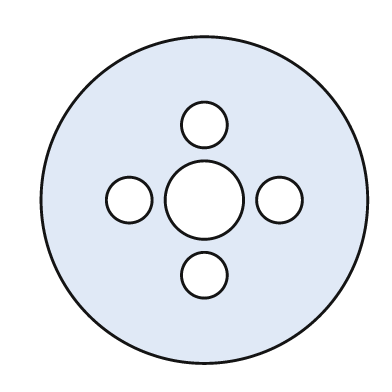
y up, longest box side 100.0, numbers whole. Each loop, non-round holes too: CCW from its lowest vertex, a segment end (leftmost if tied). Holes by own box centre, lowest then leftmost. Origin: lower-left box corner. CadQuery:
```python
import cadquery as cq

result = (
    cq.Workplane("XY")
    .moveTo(50.0, 50.0)
    .circle(50.0)
    .moveTo(50.0, 27.0)
    .circle(7.0)
    .moveTo(27.0, 50.0)
    .circle(7.0)
    .moveTo(50.0, 50.0)
    .circle(12.0)
    .moveTo(73.0, 50.0)
    .circle(7.0)
    .moveTo(50.0, 73.0)
    .circle(7.0)
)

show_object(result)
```